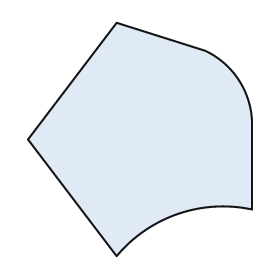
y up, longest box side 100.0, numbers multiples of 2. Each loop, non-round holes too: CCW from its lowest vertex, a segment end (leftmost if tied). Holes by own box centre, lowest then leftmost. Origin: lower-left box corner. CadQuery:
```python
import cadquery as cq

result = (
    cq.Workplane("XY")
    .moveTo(38.0, 0.0)
    .threePointArc((64.0, 18.0), (96.0, 20.0))
    .lineTo(96.0, 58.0)
    .threePointArc((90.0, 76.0), (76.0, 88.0))
    .lineTo(38.0, 100.0)
    .lineTo(0.0, 50.0)
    .close()
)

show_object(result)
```